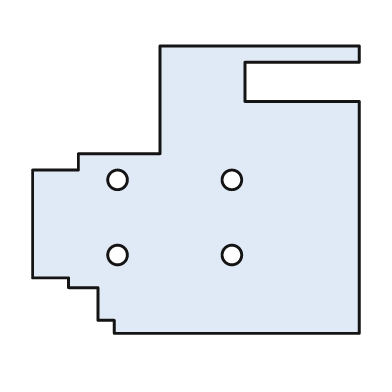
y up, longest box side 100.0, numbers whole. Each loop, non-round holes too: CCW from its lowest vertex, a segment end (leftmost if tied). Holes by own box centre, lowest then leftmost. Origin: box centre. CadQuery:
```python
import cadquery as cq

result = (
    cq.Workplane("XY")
    .moveTo(-25.0, -44.0)
    .lineTo(50.0, -44.0)
    .lineTo(50.0, 27.0)
    .lineTo(15.0, 27.0)
    .lineTo(15.0, 39.0)
    .lineTo(50.0, 39.0)
    .lineTo(50.0, 44.0)
    .lineTo(-11.0, 44.0)
    .lineTo(-11.0, 11.0)
    .lineTo(-36.0, 11.0)
    .lineTo(-36.0, 6.0)
    .lineTo(-50.0, 6.0)
    .lineTo(-50.0, -27.0)
    .lineTo(-39.0, -27.0)
    .lineTo(-39.0, -30.0)
    .lineTo(-30.0, -30.0)
    .lineTo(-30.0, -40.0)
    .lineTo(-25.0, -40.0)
    .close()
    .moveTo(-24.0, -20.0)
    .circle(3.0)
    .moveTo(11.0, -20.0)
    .circle(3.0)
    .moveTo(-24.0, 3.0)
    .circle(3.0)
    .moveTo(11.0, 3.0)
    .circle(3.0)
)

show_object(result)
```